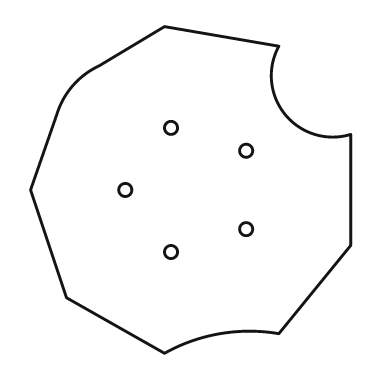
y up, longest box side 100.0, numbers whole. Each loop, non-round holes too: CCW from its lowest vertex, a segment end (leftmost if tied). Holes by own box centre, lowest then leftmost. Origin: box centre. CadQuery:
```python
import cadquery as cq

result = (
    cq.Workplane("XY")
    .moveTo(-8.0, -50.0)
    .threePointArc((9.0, -44.0), (27.0, -44.0))
    .lineTo(49.0, -17.0)
    .lineTo(49.0, 17.0)
    .threePointArc((29.0, 23.0), (27.0, 44.0))
    .lineTo(-8.0, 50.0)
    .lineTo(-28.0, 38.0)
    .threePointArc((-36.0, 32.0), (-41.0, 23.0))
    .lineTo(-49.0, 0.0)
    .lineTo(-38.0, -33.0)
    .close()
    .moveTo(-6.0, -19.0)
    .circle(2.0)
    .moveTo(17.0, -12.0)
    .circle(2.0)
    .moveTo(-20.0, 0.0)
    .circle(2.0)
    .moveTo(17.0, 12.0)
    .circle(2.0)
    .moveTo(-6.0, 19.0)
    .circle(2.0)
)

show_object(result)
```